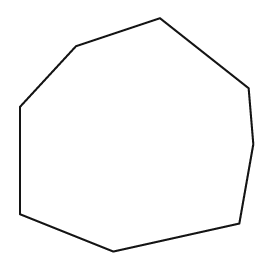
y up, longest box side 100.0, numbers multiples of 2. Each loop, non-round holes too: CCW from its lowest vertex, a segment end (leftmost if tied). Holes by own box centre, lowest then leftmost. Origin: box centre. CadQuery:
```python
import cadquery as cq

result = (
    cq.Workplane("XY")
    .moveTo(-10.0, -50.0)
    .lineTo(44.0, -38.0)
    .lineTo(50.0, -4.0)
    .lineTo(48.0, 20.0)
    .lineTo(10.0, 50.0)
    .lineTo(-26.0, 38.0)
    .lineTo(-50.0, 12.0)
    .lineTo(-50.0, -34.0)
    .close()
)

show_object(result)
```